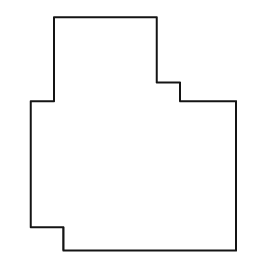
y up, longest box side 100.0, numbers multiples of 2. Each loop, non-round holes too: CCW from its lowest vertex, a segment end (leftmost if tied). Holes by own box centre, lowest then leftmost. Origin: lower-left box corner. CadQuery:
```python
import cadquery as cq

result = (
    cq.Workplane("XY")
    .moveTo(14.0, 0.0)
    .lineTo(88.0, 0.0)
    .lineTo(88.0, 64.0)
    .lineTo(64.0, 64.0)
    .lineTo(64.0, 72.0)
    .lineTo(54.0, 72.0)
    .lineTo(54.0, 100.0)
    .lineTo(10.0, 100.0)
    .lineTo(10.0, 64.0)
    .lineTo(0.0, 64.0)
    .lineTo(0.0, 10.0)
    .lineTo(14.0, 10.0)
    .close()
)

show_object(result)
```